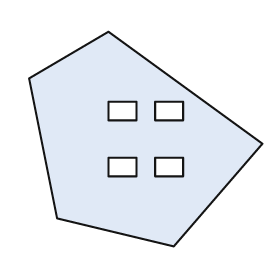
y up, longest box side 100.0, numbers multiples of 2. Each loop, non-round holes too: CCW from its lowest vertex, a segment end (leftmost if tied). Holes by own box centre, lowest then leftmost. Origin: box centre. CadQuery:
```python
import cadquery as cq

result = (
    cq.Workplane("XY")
    .moveTo(12.0, -46.0)
    .lineTo(50.0, -2.0)
    .lineTo(-16.0, 46.0)
    .lineTo(-50.0, 26.0)
    .lineTo(-38.0, -34.0)
    .close()
    .moveTo(-16.0, -16.0)
    .lineTo(-4.0, -16.0)
    .lineTo(-4.0, -8.0)
    .lineTo(-16.0, -8.0)
    .close()
    .moveTo(4.0, -16.0)
    .lineTo(16.0, -16.0)
    .lineTo(16.0, -8.0)
    .lineTo(4.0, -8.0)
    .close()
    .moveTo(-16.0, 8.0)
    .lineTo(-4.0, 8.0)
    .lineTo(-4.0, 16.0)
    .lineTo(-16.0, 16.0)
    .close()
    .moveTo(4.0, 8.0)
    .lineTo(16.0, 8.0)
    .lineTo(16.0, 16.0)
    .lineTo(4.0, 16.0)
    .close()
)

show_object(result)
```